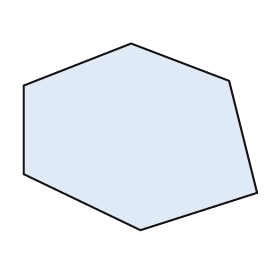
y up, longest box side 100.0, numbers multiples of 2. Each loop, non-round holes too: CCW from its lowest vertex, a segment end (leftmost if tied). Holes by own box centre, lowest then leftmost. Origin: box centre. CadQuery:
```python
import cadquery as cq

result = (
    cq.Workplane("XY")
    .moveTo(0.0, -40.0)
    .lineTo(50.0, -24.0)
    .lineTo(38.0, 24.0)
    .lineTo(-4.0, 40.0)
    .lineTo(-50.0, 22.0)
    .lineTo(-50.0, -16.0)
    .close()
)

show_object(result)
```